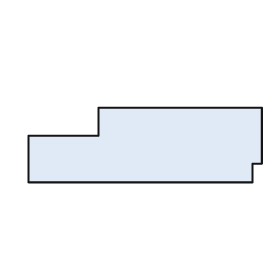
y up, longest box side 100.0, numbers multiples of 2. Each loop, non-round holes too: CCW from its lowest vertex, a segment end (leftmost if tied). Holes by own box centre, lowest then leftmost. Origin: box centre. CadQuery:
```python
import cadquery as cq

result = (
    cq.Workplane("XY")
    .moveTo(-50.0, -16.0)
    .lineTo(46.0, -16.0)
    .lineTo(46.0, -8.0)
    .lineTo(50.0, -8.0)
    .lineTo(50.0, 16.0)
    .lineTo(-20.0, 16.0)
    .lineTo(-20.0, 4.0)
    .lineTo(-50.0, 4.0)
    .close()
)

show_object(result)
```